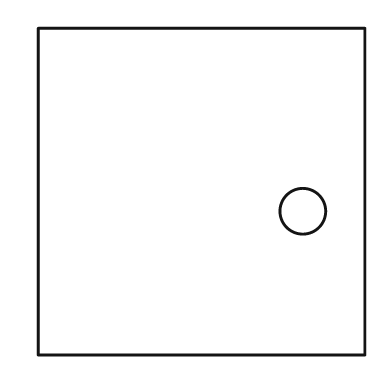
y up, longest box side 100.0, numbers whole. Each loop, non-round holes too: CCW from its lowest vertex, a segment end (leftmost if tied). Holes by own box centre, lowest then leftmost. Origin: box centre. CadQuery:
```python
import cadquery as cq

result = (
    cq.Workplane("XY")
    .moveTo(-50.0, -50.0)
    .lineTo(50.0, -50.0)
    .lineTo(50.0, 50.0)
    .lineTo(-50.0, 50.0)
    .close()
    .moveTo(31.0, -6.0)
    .circle(7.0)
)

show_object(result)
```